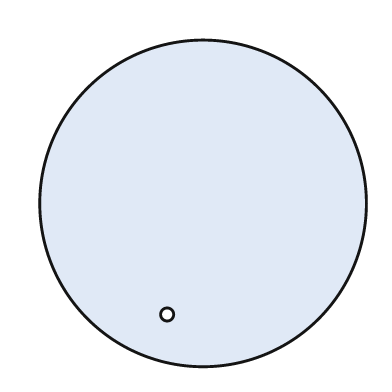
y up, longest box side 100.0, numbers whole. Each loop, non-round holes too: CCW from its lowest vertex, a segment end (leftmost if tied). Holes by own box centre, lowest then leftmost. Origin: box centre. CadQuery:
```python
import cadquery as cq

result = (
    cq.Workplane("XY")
    .moveTo(0.0, 0.0)
    .circle(50.0)
    .moveTo(-11.0, -34.0)
    .circle(2.0)
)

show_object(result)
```